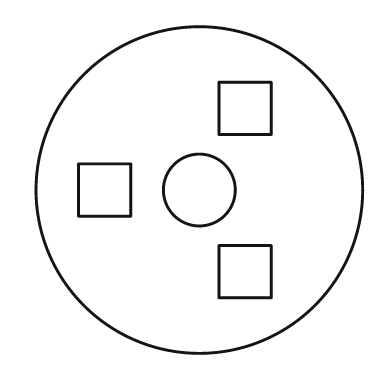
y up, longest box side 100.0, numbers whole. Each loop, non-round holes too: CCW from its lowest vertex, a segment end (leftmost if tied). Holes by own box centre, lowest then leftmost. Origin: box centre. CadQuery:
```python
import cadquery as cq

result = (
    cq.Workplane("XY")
    .moveTo(0.0, 0.0)
    .circle(50.0)
    .moveTo(6.0, -33.0)
    .lineTo(22.0, -33.0)
    .lineTo(22.0, -17.0)
    .lineTo(6.0, -17.0)
    .close()
    .moveTo(-37.0, -8.0)
    .lineTo(-21.0, -8.0)
    .lineTo(-21.0, 8.0)
    .lineTo(-37.0, 8.0)
    .close()
    .moveTo(0.0, 0.0)
    .circle(11.0)
    .moveTo(6.0, 17.0)
    .lineTo(22.0, 17.0)
    .lineTo(22.0, 33.0)
    .lineTo(6.0, 33.0)
    .close()
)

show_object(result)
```